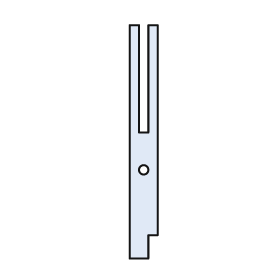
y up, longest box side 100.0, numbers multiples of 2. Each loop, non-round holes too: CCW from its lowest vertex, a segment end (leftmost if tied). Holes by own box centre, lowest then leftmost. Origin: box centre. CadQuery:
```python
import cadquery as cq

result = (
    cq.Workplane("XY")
    .moveTo(-6.0, -50.0)
    .lineTo(2.0, -50.0)
    .lineTo(2.0, -40.0)
    .lineTo(6.0, -40.0)
    .lineTo(6.0, 50.0)
    .lineTo(2.0, 50.0)
    .lineTo(2.0, 4.0)
    .lineTo(-2.0, 4.0)
    .lineTo(-2.0, 50.0)
    .lineTo(-6.0, 50.0)
    .close()
    .moveTo(0.0, -12.0)
    .circle(2.0)
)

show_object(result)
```